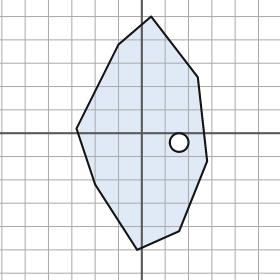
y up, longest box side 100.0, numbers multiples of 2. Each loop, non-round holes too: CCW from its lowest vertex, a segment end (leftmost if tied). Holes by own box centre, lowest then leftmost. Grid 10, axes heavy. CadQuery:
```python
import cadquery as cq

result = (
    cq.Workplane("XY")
    .moveTo(-2.0, -50.0)
    .lineTo(16.0, -42.0)
    .lineTo(28.0, -12.0)
    .lineTo(24.0, 24.0)
    .lineTo(4.0, 50.0)
    .lineTo(-10.0, 38.0)
    .lineTo(-28.0, 2.0)
    .lineTo(-20.0, -22.0)
    .close()
    .moveTo(16.0, -4.0)
    .circle(4.0)
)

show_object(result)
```